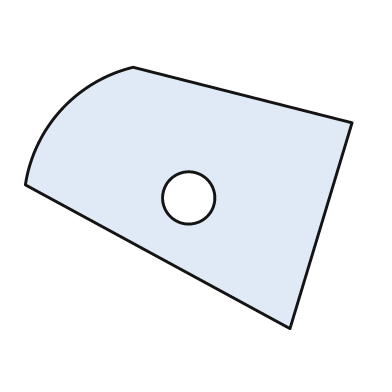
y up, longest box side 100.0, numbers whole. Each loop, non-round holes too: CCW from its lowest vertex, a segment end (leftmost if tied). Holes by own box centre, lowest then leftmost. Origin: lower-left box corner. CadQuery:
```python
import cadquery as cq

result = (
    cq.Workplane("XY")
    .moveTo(81.0, 0.0)
    .lineTo(100.0, 63.0)
    .lineTo(33.0, 80.0)
    .threePointArc((11.0, 67.0), (0.0, 44.0))
    .close()
    .moveTo(50.0, 40.0)
    .circle(8.0)
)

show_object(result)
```